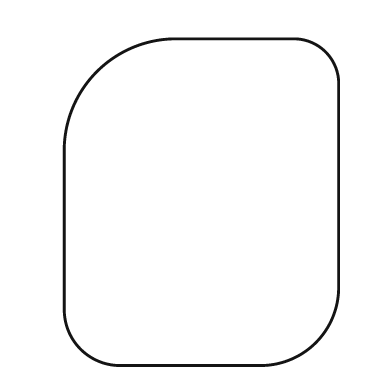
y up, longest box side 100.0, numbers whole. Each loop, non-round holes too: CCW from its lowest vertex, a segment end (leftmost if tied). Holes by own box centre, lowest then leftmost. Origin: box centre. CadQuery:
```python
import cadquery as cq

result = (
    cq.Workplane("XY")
    .moveTo(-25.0, -50.0)
    .lineTo(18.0, -50.0)
    .threePointArc((35.0, -43.0), (42.0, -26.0))
    .lineTo(42.0, 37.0)
    .threePointArc((38.0, 46.0), (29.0, 50.0))
    .lineTo(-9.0, 50.0)
    .threePointArc((-32.0, 40.0), (-42.0, 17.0))
    .lineTo(-42.0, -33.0)
    .threePointArc((-37.0, -45.0), (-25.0, -50.0))
    .close()
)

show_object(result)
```